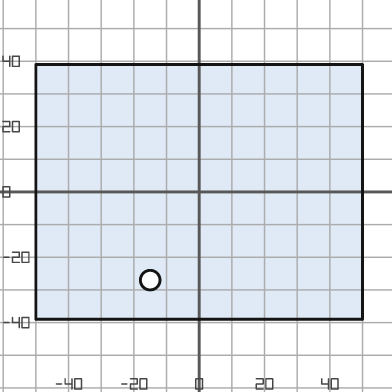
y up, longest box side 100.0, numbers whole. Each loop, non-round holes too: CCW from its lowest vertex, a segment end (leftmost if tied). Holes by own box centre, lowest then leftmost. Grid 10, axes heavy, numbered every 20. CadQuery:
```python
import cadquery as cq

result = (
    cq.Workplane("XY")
    .moveTo(-50.0, -39.0)
    .lineTo(50.0, -39.0)
    .lineTo(50.0, 39.0)
    .lineTo(-50.0, 39.0)
    .close()
    .moveTo(-15.0, -27.0)
    .circle(3.0)
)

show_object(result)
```